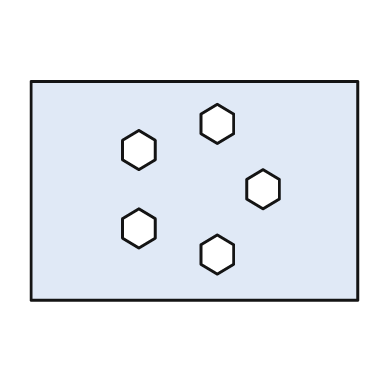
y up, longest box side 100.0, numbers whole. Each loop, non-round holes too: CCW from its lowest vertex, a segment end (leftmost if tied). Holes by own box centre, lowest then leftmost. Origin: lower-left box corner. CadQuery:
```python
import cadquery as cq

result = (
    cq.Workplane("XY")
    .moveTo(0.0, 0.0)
    .lineTo(100.0, 0.0)
    .lineTo(100.0, 67.0)
    .lineTo(0.0, 67.0)
    .close()
    .moveTo(57.0, 8.0)
    .lineTo(62.0, 11.0)
    .lineTo(62.0, 17.0)
    .lineTo(57.0, 20.0)
    .lineTo(52.0, 17.0)
    .lineTo(52.0, 11.0)
    .close()
    .moveTo(33.0, 16.0)
    .lineTo(38.0, 19.0)
    .lineTo(38.0, 25.0)
    .lineTo(33.0, 28.0)
    .lineTo(28.0, 25.0)
    .lineTo(28.0, 19.0)
    .close()
    .moveTo(71.0, 28.0)
    .lineTo(76.0, 31.0)
    .lineTo(76.0, 37.0)
    .lineTo(71.0, 40.0)
    .lineTo(66.0, 37.0)
    .lineTo(66.0, 31.0)
    .close()
    .moveTo(33.0, 40.0)
    .lineTo(38.0, 43.0)
    .lineTo(38.0, 49.0)
    .lineTo(33.0, 52.0)
    .lineTo(28.0, 49.0)
    .lineTo(28.0, 43.0)
    .close()
    .moveTo(57.0, 48.0)
    .lineTo(62.0, 51.0)
    .lineTo(62.0, 57.0)
    .lineTo(57.0, 60.0)
    .lineTo(52.0, 57.0)
    .lineTo(52.0, 51.0)
    .close()
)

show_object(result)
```